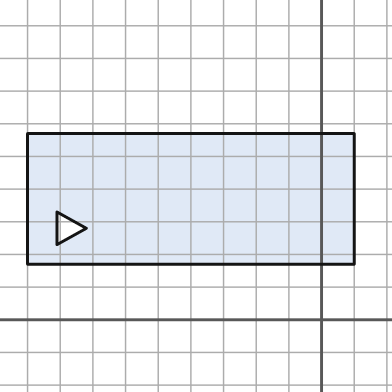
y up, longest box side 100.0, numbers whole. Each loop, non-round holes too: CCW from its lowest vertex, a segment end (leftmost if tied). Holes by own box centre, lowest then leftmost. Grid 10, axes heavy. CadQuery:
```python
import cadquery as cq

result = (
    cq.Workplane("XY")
    .moveTo(-90.0, 17.0)
    .lineTo(10.0, 17.0)
    .lineTo(10.0, 57.0)
    .lineTo(-90.0, 57.0)
    .close()
    .moveTo(-81.0, 23.0)
    .lineTo(-72.0, 28.0)
    .lineTo(-81.0, 33.0)
    .close()
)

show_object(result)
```